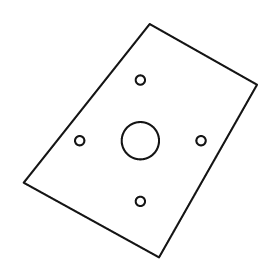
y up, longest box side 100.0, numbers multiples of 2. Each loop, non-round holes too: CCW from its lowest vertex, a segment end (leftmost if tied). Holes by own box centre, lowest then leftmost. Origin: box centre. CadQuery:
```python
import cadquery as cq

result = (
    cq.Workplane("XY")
    .moveTo(8.0, -50.0)
    .lineTo(50.0, 24.0)
    .lineTo(4.0, 50.0)
    .lineTo(-50.0, -18.0)
    .close()
    .moveTo(0.0, -26.0)
    .circle(2.0)
    .moveTo(-26.0, 0.0)
    .circle(2.0)
    .moveTo(0.0, 0.0)
    .circle(8.0)
    .moveTo(26.0, 0.0)
    .circle(2.0)
    .moveTo(0.0, 26.0)
    .circle(2.0)
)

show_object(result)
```